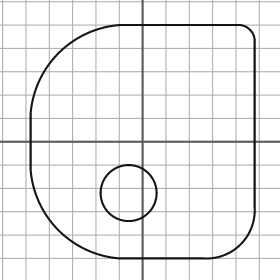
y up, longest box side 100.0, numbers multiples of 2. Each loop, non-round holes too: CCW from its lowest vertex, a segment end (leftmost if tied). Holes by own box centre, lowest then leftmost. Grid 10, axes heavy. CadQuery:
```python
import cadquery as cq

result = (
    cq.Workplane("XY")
    .moveTo(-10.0, -50.0)
    .lineTo(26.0, -50.0)
    .threePointArc((42.0, -44.0), (48.0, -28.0))
    .lineTo(48.0, 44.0)
    .threePointArc((46.0, 48.0), (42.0, 50.0))
    .lineTo(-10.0, 50.0)
    .threePointArc((-36.0, 38.0), (-48.0, 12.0))
    .lineTo(-48.0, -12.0)
    .threePointArc((-36.0, -38.0), (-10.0, -50.0))
    .close()
    .moveTo(-6.0, -22.0)
    .circle(12.0)
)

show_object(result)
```